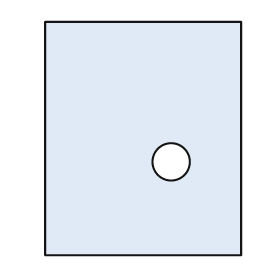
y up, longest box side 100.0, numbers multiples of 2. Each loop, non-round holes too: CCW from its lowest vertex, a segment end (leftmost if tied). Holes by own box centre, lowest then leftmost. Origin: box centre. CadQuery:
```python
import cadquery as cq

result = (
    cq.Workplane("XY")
    .moveTo(-42.0, -50.0)
    .lineTo(42.0, -50.0)
    .lineTo(42.0, 50.0)
    .lineTo(-42.0, 50.0)
    .close()
    .moveTo(12.0, -10.0)
    .circle(8.0)
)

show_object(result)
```